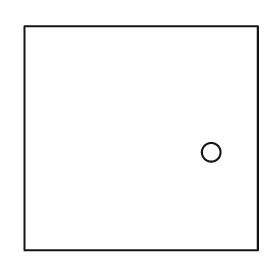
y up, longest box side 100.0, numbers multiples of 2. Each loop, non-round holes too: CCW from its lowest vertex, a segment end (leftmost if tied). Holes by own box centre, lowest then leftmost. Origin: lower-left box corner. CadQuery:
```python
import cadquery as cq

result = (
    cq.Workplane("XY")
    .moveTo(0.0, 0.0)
    .lineTo(100.0, 0.0)
    .lineTo(100.0, 96.0)
    .lineTo(0.0, 96.0)
    .close()
    .moveTo(80.0, 42.0)
    .circle(4.0)
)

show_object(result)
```